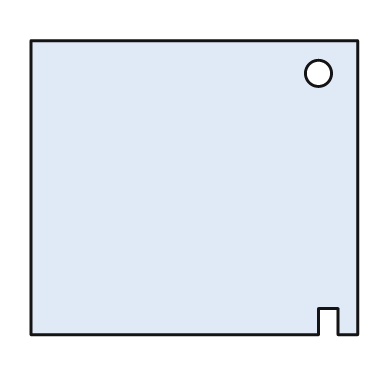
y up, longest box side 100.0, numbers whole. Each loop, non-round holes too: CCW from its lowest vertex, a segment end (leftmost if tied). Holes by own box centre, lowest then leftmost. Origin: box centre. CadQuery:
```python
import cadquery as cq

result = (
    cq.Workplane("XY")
    .moveTo(-50.0, -45.0)
    .lineTo(38.0, -45.0)
    .lineTo(38.0, -37.0)
    .lineTo(44.0, -37.0)
    .lineTo(44.0, -45.0)
    .lineTo(50.0, -45.0)
    .lineTo(50.0, 45.0)
    .lineTo(-50.0, 45.0)
    .close()
    .moveTo(38.0, 35.0)
    .circle(4.0)
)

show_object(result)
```